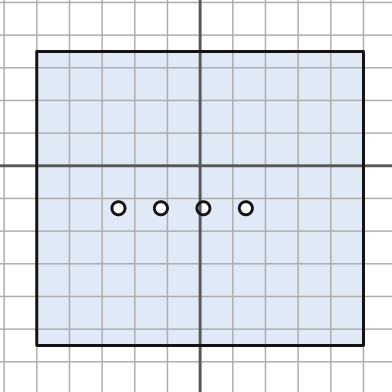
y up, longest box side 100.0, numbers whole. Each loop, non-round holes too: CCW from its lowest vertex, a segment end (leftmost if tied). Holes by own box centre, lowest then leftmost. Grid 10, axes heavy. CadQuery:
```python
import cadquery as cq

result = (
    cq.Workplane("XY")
    .moveTo(-50.0, -55.0)
    .lineTo(50.0, -55.0)
    .lineTo(50.0, 35.0)
    .lineTo(-50.0, 35.0)
    .close()
    .moveTo(-25.0, -13.0)
    .circle(2.0)
    .moveTo(-12.0, -13.0)
    .circle(2.0)
    .moveTo(1.0, -13.0)
    .circle(2.0)
    .moveTo(14.0, -13.0)
    .circle(2.0)
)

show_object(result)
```